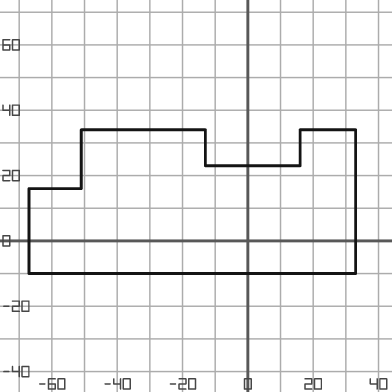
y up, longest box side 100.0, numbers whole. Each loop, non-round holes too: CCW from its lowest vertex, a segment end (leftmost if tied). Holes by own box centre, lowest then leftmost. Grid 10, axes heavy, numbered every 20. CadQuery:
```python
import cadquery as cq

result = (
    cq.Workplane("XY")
    .moveTo(-67.0, -10.0)
    .lineTo(33.0, -10.0)
    .lineTo(33.0, 34.0)
    .lineTo(16.0, 34.0)
    .lineTo(16.0, 23.0)
    .lineTo(-13.0, 23.0)
    .lineTo(-13.0, 34.0)
    .lineTo(-51.0, 34.0)
    .lineTo(-51.0, 16.0)
    .lineTo(-67.0, 16.0)
    .close()
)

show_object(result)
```